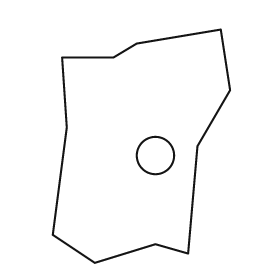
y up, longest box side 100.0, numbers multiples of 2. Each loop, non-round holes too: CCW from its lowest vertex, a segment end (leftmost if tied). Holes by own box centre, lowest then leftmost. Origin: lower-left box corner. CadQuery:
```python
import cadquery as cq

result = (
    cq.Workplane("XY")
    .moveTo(18.0, 0.0)
    .lineTo(44.0, 8.0)
    .lineTo(58.0, 4.0)
    .lineTo(62.0, 50.0)
    .lineTo(76.0, 74.0)
    .lineTo(72.0, 100.0)
    .lineTo(36.0, 94.0)
    .lineTo(26.0, 88.0)
    .lineTo(4.0, 88.0)
    .lineTo(6.0, 58.0)
    .lineTo(0.0, 12.0)
    .close()
    .moveTo(44.0, 46.0)
    .circle(8.0)
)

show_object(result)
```